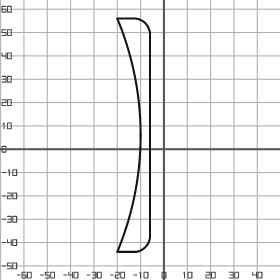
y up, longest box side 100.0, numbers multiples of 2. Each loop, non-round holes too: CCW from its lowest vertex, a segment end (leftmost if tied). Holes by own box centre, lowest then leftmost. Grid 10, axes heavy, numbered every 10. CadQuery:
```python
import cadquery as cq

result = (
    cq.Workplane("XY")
    .moveTo(-20.0, -44.0)
    .lineTo(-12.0, -44.0)
    .threePointArc((-8.0, -42.0), (-6.0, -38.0))
    .lineTo(-6.0, 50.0)
    .threePointArc((-8.0, 54.0), (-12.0, 56.0))
    .lineTo(-20.0, 56.0)
    .threePointArc((-10.0, 6.0), (-20.0, -44.0))
    .close()
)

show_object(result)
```